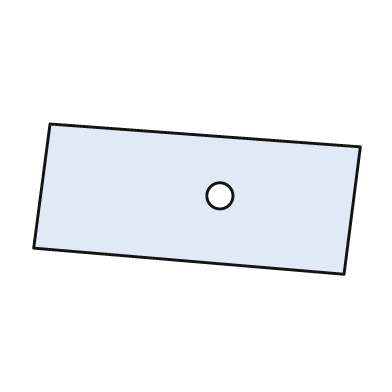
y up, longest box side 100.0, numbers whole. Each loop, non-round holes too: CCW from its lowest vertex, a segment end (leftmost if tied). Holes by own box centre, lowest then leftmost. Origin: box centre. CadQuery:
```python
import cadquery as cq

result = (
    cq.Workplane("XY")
    .moveTo(45.0, -23.0)
    .lineTo(50.0, 16.0)
    .lineTo(-45.0, 23.0)
    .lineTo(-50.0, -15.0)
    .close()
    .moveTo(7.0, 1.0)
    .circle(4.0)
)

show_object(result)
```